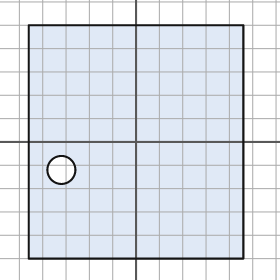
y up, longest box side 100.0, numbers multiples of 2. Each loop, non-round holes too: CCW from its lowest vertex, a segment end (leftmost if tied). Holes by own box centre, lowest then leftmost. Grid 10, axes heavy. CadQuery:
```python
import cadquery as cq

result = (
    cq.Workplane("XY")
    .moveTo(-46.0, -50.0)
    .lineTo(46.0, -50.0)
    .lineTo(46.0, 50.0)
    .lineTo(-46.0, 50.0)
    .close()
    .moveTo(-32.0, -12.0)
    .circle(6.0)
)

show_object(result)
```